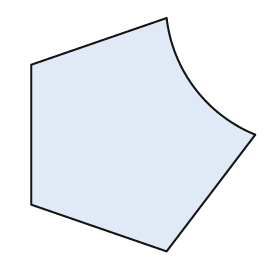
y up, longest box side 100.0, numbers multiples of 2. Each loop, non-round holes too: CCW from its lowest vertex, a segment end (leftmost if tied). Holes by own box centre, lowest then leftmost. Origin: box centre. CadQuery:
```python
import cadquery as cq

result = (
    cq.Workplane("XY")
    .moveTo(10.0, -50.0)
    .lineTo(48.0, 0.0)
    .threePointArc((22.0, 20.0), (10.0, 50.0))
    .lineTo(-48.0, 30.0)
    .lineTo(-48.0, -30.0)
    .close()
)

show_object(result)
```